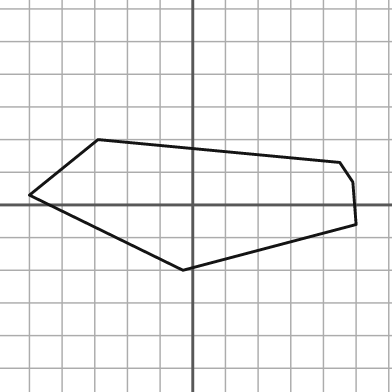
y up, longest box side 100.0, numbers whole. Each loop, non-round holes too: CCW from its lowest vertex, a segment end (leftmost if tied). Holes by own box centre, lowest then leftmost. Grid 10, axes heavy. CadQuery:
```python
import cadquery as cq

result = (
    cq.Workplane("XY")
    .moveTo(-3.0, -20.0)
    .lineTo(50.0, -6.0)
    .lineTo(49.0, 7.0)
    .lineTo(45.0, 13.0)
    .lineTo(-29.0, 20.0)
    .lineTo(-50.0, 3.0)
    .close()
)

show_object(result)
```